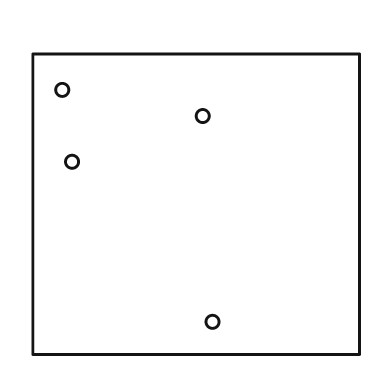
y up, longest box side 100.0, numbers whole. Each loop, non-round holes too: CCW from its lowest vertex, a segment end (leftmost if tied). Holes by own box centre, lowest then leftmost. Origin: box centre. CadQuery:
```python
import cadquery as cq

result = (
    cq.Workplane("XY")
    .moveTo(-50.0, -46.0)
    .lineTo(50.0, -46.0)
    .lineTo(50.0, 46.0)
    .lineTo(-50.0, 46.0)
    .close()
    .moveTo(5.0, -36.0)
    .circle(2.0)
    .moveTo(-38.0, 13.0)
    .circle(2.0)
    .moveTo(2.0, 27.0)
    .circle(2.0)
    .moveTo(-41.0, 35.0)
    .circle(2.0)
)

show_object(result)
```